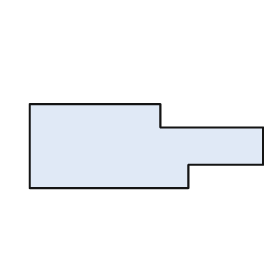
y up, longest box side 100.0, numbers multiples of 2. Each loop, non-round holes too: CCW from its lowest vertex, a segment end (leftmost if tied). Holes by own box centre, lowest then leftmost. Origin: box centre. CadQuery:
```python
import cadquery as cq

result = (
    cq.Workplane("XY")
    .moveTo(-50.0, -18.0)
    .lineTo(18.0, -18.0)
    .lineTo(18.0, -8.0)
    .lineTo(50.0, -8.0)
    .lineTo(50.0, 8.0)
    .lineTo(6.0, 8.0)
    .lineTo(6.0, 18.0)
    .lineTo(-50.0, 18.0)
    .close()
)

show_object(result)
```